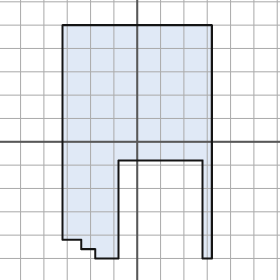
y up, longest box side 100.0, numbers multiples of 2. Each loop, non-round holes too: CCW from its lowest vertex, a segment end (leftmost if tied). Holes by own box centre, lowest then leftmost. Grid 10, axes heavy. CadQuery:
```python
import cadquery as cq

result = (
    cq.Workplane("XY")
    .moveTo(-18.0, -50.0)
    .lineTo(-8.0, -50.0)
    .lineTo(-8.0, -8.0)
    .lineTo(28.0, -8.0)
    .lineTo(28.0, -50.0)
    .lineTo(32.0, -50.0)
    .lineTo(32.0, 50.0)
    .lineTo(-32.0, 50.0)
    .lineTo(-32.0, -42.0)
    .lineTo(-24.0, -42.0)
    .lineTo(-24.0, -46.0)
    .lineTo(-18.0, -46.0)
    .close()
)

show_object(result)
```